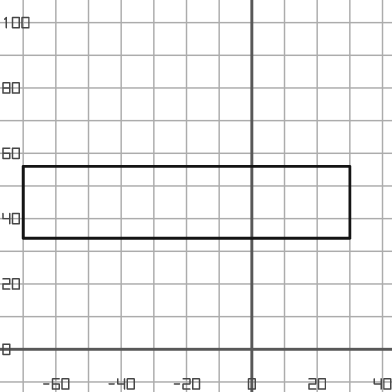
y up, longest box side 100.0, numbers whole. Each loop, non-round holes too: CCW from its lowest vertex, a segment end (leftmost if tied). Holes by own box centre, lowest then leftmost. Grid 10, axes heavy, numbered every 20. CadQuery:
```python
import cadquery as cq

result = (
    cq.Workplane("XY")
    .moveTo(-70.0, 34.0)
    .lineTo(30.0, 34.0)
    .lineTo(30.0, 56.0)
    .lineTo(-70.0, 56.0)
    .close()
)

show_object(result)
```